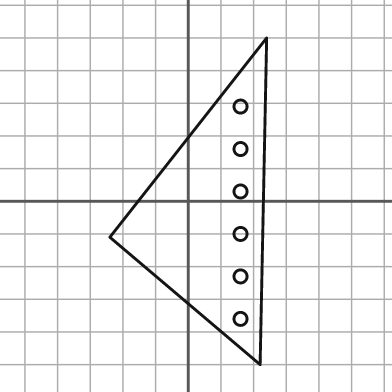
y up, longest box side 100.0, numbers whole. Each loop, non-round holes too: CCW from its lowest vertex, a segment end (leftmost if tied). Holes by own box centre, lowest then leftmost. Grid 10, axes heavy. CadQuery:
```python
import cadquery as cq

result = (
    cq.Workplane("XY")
    .moveTo(22.0, -50.0)
    .lineTo(24.0, 50.0)
    .lineTo(-24.0, -11.0)
    .close()
    .moveTo(16.0, -36.0)
    .circle(2.0)
    .moveTo(16.0, -23.0)
    .circle(2.0)
    .moveTo(16.0, -10.0)
    .circle(2.0)
    .moveTo(16.0, 3.0)
    .circle(2.0)
    .moveTo(16.0, 16.0)
    .circle(2.0)
    .moveTo(16.0, 29.0)
    .circle(2.0)
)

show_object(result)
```